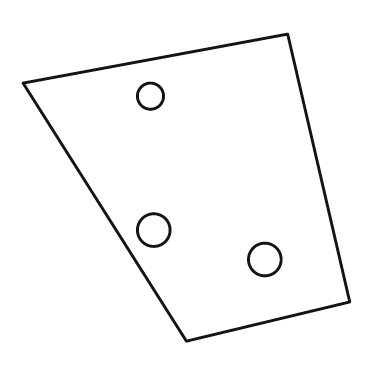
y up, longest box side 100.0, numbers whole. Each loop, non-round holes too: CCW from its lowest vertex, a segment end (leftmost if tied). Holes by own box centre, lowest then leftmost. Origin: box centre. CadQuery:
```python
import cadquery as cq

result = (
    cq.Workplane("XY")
    .moveTo(0.0, -47.0)
    .lineTo(50.0, -35.0)
    .lineTo(31.0, 47.0)
    .lineTo(-50.0, 32.0)
    .close()
    .moveTo(24.0, -22.0)
    .circle(5.0)
    .moveTo(-10.0, -13.0)
    .circle(5.0)
    .moveTo(-11.0, 28.0)
    .circle(4.0)
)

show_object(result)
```